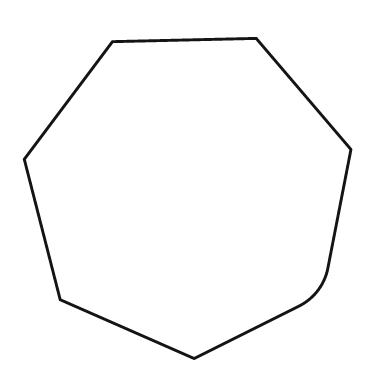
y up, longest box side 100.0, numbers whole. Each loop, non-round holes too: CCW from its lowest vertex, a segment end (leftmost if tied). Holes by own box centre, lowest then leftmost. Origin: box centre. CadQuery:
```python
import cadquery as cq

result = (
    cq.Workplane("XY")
    .moveTo(2.0, -49.0)
    .lineTo(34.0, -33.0)
    .threePointArc((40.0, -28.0), (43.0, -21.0))
    .lineTo(50.0, 15.0)
    .lineTo(21.0, 49.0)
    .lineTo(-23.0, 48.0)
    .lineTo(-50.0, 12.0)
    .lineTo(-39.0, -31.0)
    .close()
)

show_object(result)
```